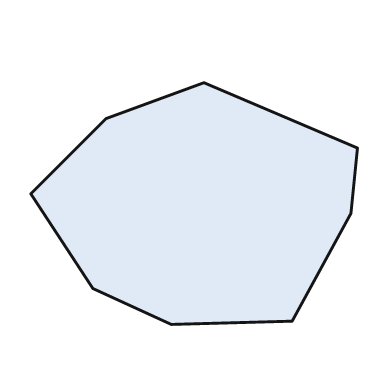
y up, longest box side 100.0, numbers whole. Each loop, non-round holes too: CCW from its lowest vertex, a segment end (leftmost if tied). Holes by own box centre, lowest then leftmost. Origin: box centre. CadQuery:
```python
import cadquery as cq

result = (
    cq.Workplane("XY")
    .moveTo(-7.0, -37.0)
    .lineTo(30.0, -36.0)
    .lineTo(48.0, -3.0)
    .lineTo(50.0, 17.0)
    .lineTo(3.0, 37.0)
    .lineTo(-27.0, 26.0)
    .lineTo(-50.0, 3.0)
    .lineTo(-31.0, -26.0)
    .close()
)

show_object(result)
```